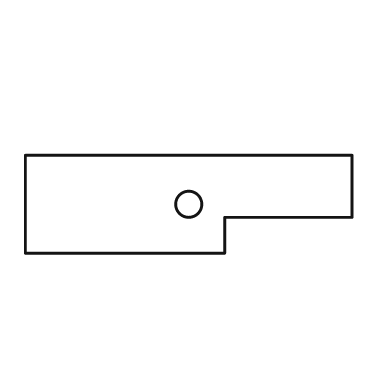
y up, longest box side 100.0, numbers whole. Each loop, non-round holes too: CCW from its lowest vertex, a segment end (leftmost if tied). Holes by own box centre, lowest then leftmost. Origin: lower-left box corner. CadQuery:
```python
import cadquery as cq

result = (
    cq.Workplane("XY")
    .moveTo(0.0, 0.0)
    .lineTo(61.0, 0.0)
    .lineTo(61.0, 11.0)
    .lineTo(100.0, 11.0)
    .lineTo(100.0, 30.0)
    .lineTo(0.0, 30.0)
    .close()
    .moveTo(50.0, 15.0)
    .circle(4.0)
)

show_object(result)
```